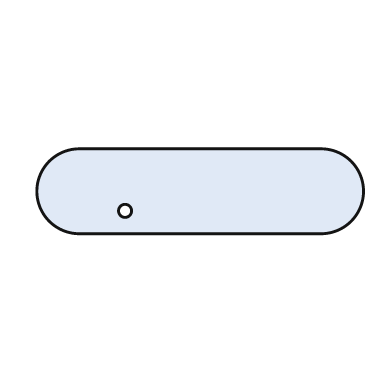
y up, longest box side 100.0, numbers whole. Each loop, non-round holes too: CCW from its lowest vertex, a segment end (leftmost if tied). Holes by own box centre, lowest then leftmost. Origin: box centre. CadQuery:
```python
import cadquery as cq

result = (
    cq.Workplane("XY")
    .moveTo(-37.0, -13.0)
    .lineTo(37.0, -13.0)
    .threePointArc((50.0, 0.0), (37.0, 13.0))
    .lineTo(-37.0, 13.0)
    .threePointArc((-50.0, 0.0), (-37.0, -13.0))
    .close()
    .moveTo(-23.0, -6.0)
    .circle(2.0)
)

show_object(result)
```